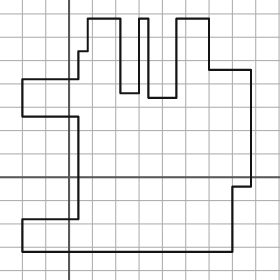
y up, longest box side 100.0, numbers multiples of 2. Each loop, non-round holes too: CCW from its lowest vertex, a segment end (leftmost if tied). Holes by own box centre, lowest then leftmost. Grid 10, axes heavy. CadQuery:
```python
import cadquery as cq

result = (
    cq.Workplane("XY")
    .moveTo(-20.0, -32.0)
    .lineTo(70.0, -32.0)
    .lineTo(70.0, -4.0)
    .lineTo(78.0, -4.0)
    .lineTo(78.0, 46.0)
    .lineTo(60.0, 46.0)
    .lineTo(60.0, 68.0)
    .lineTo(46.0, 68.0)
    .lineTo(46.0, 34.0)
    .lineTo(34.0, 34.0)
    .lineTo(34.0, 68.0)
    .lineTo(30.0, 68.0)
    .lineTo(30.0, 36.0)
    .lineTo(22.0, 36.0)
    .lineTo(22.0, 68.0)
    .lineTo(8.0, 68.0)
    .lineTo(8.0, 54.0)
    .lineTo(4.0, 54.0)
    .lineTo(4.0, 42.0)
    .lineTo(-20.0, 42.0)
    .lineTo(-20.0, 26.0)
    .lineTo(4.0, 26.0)
    .lineTo(4.0, -18.0)
    .lineTo(-20.0, -18.0)
    .close()
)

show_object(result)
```